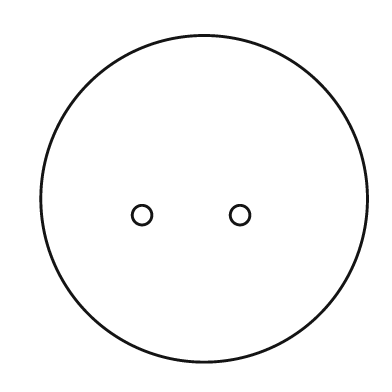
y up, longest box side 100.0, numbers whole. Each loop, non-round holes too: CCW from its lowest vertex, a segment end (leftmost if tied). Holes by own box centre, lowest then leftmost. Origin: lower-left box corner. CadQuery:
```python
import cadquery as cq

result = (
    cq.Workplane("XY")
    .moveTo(50.0, 50.0)
    .circle(50.0)
    .moveTo(31.0, 45.0)
    .circle(3.0)
    .moveTo(61.0, 45.0)
    .circle(3.0)
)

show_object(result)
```